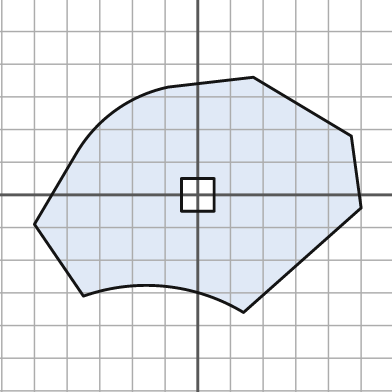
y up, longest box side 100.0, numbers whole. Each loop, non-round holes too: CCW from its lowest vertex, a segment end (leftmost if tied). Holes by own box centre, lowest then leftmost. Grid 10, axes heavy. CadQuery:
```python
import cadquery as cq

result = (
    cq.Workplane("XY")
    .moveTo(14.0, -36.0)
    .lineTo(50.0, -4.0)
    .lineTo(47.0, 18.0)
    .lineTo(17.0, 36.0)
    .lineTo(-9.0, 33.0)
    .threePointArc((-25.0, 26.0), (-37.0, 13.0))
    .lineTo(-50.0, -9.0)
    .lineTo(-35.0, -31.0)
    .threePointArc((-10.0, -28.0), (14.0, -36.0))
    .close()
    .moveTo(-5.0, -5.0)
    .lineTo(5.0, -5.0)
    .lineTo(5.0, 5.0)
    .lineTo(-5.0, 5.0)
    .close()
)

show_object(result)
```